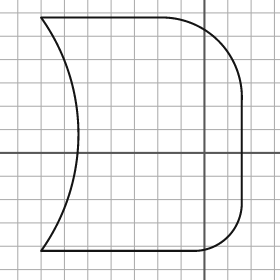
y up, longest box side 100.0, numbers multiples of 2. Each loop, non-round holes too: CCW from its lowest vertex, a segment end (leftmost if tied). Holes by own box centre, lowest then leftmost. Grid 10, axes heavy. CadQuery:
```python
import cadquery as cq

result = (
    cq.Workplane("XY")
    .moveTo(-70.0, -42.0)
    .lineTo(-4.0, -42.0)
    .threePointArc((10.0, -36.0), (16.0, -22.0))
    .lineTo(16.0, 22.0)
    .threePointArc((6.0, 48.0), (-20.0, 58.0))
    .lineTo(-70.0, 58.0)
    .threePointArc((-54.0, 8.0), (-70.0, -42.0))
    .close()
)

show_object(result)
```